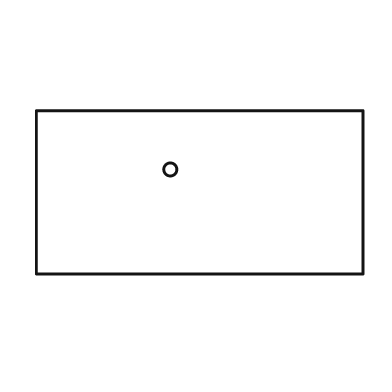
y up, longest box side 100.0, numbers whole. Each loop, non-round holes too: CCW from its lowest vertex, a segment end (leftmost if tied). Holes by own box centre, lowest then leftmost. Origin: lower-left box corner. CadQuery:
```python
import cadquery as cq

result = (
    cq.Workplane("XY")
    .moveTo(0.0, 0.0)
    .lineTo(100.0, 0.0)
    .lineTo(100.0, 50.0)
    .lineTo(0.0, 50.0)
    .close()
    .moveTo(41.0, 32.0)
    .circle(2.0)
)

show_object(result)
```